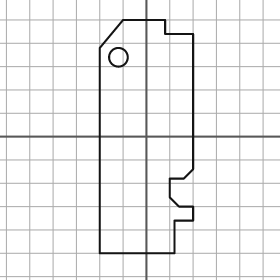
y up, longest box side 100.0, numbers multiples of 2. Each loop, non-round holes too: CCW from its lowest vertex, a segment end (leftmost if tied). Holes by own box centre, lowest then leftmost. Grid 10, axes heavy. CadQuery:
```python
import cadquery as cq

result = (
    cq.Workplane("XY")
    .moveTo(-20.0, -50.0)
    .lineTo(12.0, -50.0)
    .lineTo(12.0, -36.0)
    .lineTo(20.0, -36.0)
    .lineTo(20.0, -30.0)
    .lineTo(14.0, -30.0)
    .lineTo(10.0, -26.0)
    .lineTo(10.0, -18.0)
    .lineTo(16.0, -18.0)
    .lineTo(20.0, -14.0)
    .lineTo(20.0, 44.0)
    .lineTo(8.0, 44.0)
    .lineTo(8.0, 50.0)
    .lineTo(-10.0, 50.0)
    .lineTo(-20.0, 38.0)
    .close()
    .moveTo(-12.0, 34.0)
    .circle(4.0)
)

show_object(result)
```